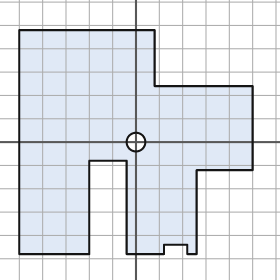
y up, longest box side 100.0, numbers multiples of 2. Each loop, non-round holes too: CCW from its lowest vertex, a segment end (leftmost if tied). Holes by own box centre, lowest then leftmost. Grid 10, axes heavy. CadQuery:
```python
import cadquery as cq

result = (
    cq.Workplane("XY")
    .moveTo(-50.0, -48.0)
    .lineTo(-20.0, -48.0)
    .lineTo(-20.0, -8.0)
    .lineTo(-4.0, -8.0)
    .lineTo(-4.0, -48.0)
    .lineTo(12.0, -48.0)
    .lineTo(12.0, -44.0)
    .lineTo(22.0, -44.0)
    .lineTo(22.0, -48.0)
    .lineTo(26.0, -48.0)
    .lineTo(26.0, -12.0)
    .lineTo(50.0, -12.0)
    .lineTo(50.0, 24.0)
    .lineTo(8.0, 24.0)
    .lineTo(8.0, 48.0)
    .lineTo(-50.0, 48.0)
    .close()
    .moveTo(0.0, 0.0)
    .circle(4.0)
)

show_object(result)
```